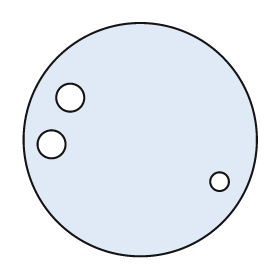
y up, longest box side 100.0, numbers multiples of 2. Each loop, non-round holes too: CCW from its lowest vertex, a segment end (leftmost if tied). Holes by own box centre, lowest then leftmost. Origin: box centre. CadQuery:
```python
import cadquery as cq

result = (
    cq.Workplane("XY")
    .moveTo(0.0, 0.0)
    .circle(50.0)
    .moveTo(34.0, -18.0)
    .circle(4.0)
    .moveTo(-38.0, -2.0)
    .circle(6.0)
    .moveTo(-30.0, 18.0)
    .circle(6.0)
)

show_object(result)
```